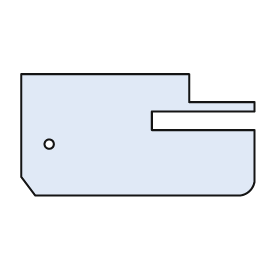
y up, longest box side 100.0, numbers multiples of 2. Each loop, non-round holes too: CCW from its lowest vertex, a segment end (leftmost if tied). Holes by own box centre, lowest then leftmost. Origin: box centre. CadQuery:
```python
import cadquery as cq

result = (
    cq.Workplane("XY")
    .moveTo(-44.0, -26.0)
    .lineTo(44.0, -26.0)
    .threePointArc((48.0, -24.0), (50.0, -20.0))
    .lineTo(50.0, 2.0)
    .lineTo(6.0, 2.0)
    .lineTo(6.0, 10.0)
    .lineTo(50.0, 10.0)
    .lineTo(50.0, 14.0)
    .lineTo(22.0, 14.0)
    .lineTo(22.0, 26.0)
    .lineTo(-50.0, 26.0)
    .lineTo(-50.0, -18.0)
    .close()
    .moveTo(-38.0, -4.0)
    .circle(2.0)
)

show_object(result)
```